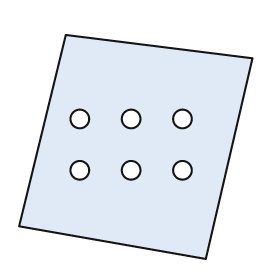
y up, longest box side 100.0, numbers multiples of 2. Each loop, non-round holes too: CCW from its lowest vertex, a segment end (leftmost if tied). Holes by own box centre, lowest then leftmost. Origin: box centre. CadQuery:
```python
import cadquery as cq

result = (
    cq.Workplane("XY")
    .moveTo(30.0, -48.0)
    .lineTo(50.0, 38.0)
    .lineTo(-30.0, 48.0)
    .lineTo(-50.0, -34.0)
    .close()
    .moveTo(-24.0, -10.0)
    .circle(4.0)
    .moveTo(-2.0, -10.0)
    .circle(4.0)
    .moveTo(20.0, -10.0)
    .circle(4.0)
    .moveTo(-24.0, 12.0)
    .circle(4.0)
    .moveTo(-2.0, 12.0)
    .circle(4.0)
    .moveTo(20.0, 12.0)
    .circle(4.0)
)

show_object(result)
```